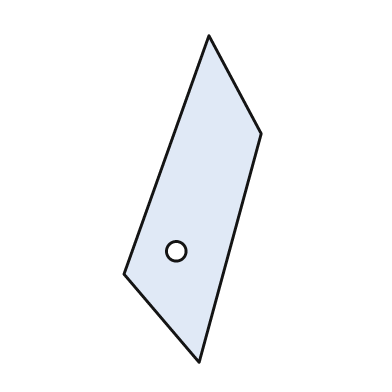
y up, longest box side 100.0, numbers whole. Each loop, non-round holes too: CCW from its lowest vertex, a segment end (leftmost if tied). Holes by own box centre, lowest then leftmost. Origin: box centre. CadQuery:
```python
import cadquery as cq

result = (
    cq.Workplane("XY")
    .moveTo(2.0, -50.0)
    .lineTo(21.0, 20.0)
    .lineTo(5.0, 50.0)
    .lineTo(-21.0, -23.0)
    .close()
    .moveTo(-5.0, -16.0)
    .circle(3.0)
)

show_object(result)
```